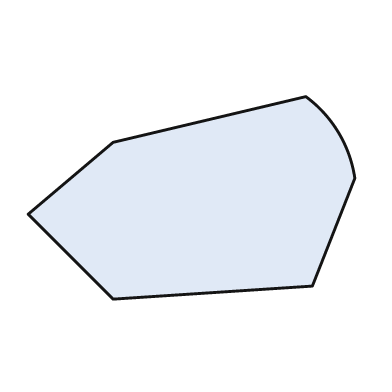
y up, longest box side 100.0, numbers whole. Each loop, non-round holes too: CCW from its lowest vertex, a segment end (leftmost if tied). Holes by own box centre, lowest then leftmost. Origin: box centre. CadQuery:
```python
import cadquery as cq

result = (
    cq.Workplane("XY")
    .moveTo(-24.0, -31.0)
    .lineTo(37.0, -27.0)
    .lineTo(50.0, 6.0)
    .threePointArc((45.0, 20.0), (35.0, 31.0))
    .lineTo(-24.0, 17.0)
    .lineTo(-50.0, -5.0)
    .close()
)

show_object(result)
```